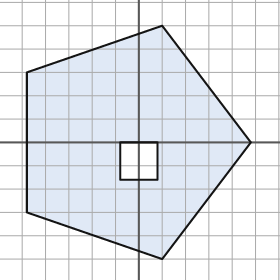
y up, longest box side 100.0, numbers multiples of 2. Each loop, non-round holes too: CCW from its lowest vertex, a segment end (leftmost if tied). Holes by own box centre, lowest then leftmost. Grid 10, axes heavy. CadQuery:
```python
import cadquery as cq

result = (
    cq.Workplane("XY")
    .moveTo(10.0, -50.0)
    .lineTo(48.0, 0.0)
    .lineTo(10.0, 50.0)
    .lineTo(-48.0, 30.0)
    .lineTo(-48.0, -30.0)
    .close()
    .moveTo(-8.0, -16.0)
    .lineTo(8.0, -16.0)
    .lineTo(8.0, 0.0)
    .lineTo(-8.0, 0.0)
    .close()
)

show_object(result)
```